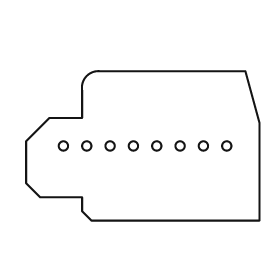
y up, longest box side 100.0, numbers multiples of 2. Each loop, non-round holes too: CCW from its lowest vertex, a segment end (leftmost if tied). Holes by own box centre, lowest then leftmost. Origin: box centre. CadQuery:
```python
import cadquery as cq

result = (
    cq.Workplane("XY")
    .moveTo(-22.0, -32.0)
    .lineTo(50.0, -32.0)
    .lineTo(50.0, 10.0)
    .lineTo(44.0, 32.0)
    .lineTo(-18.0, 32.0)
    .threePointArc((-24.0, 30.0), (-26.0, 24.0))
    .lineTo(-26.0, 12.0)
    .lineTo(-40.0, 12.0)
    .lineTo(-50.0, 2.0)
    .lineTo(-50.0, -16.0)
    .lineTo(-44.0, -22.0)
    .lineTo(-26.0, -22.0)
    .lineTo(-26.0, -28.0)
    .close()
    .moveTo(-34.0, 0.0)
    .circle(2.0)
    .moveTo(-24.0, 0.0)
    .circle(2.0)
    .moveTo(-14.0, 0.0)
    .circle(2.0)
    .moveTo(-4.0, 0.0)
    .circle(2.0)
    .moveTo(6.0, 0.0)
    .circle(2.0)
    .moveTo(16.0, 0.0)
    .circle(2.0)
    .moveTo(26.0, 0.0)
    .circle(2.0)
    .moveTo(36.0, 0.0)
    .circle(2.0)
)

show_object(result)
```